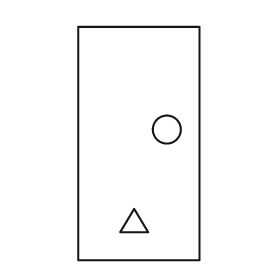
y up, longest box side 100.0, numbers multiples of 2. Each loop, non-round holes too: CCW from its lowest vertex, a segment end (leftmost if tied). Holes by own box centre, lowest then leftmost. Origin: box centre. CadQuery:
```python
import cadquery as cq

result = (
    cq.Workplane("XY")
    .moveTo(-26.0, -50.0)
    .lineTo(26.0, -50.0)
    .lineTo(26.0, 50.0)
    .lineTo(-26.0, 50.0)
    .close()
    .moveTo(-8.0, -38.0)
    .lineTo(4.0, -38.0)
    .lineTo(-2.0, -28.0)
    .close()
    .moveTo(12.0, 6.0)
    .circle(6.0)
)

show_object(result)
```